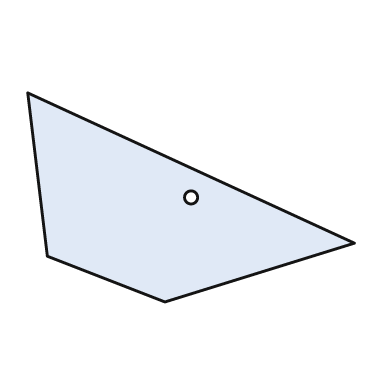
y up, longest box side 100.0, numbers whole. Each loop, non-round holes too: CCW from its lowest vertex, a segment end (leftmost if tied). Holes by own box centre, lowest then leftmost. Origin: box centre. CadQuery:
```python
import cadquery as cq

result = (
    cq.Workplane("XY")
    .moveTo(-8.0, -32.0)
    .lineTo(50.0, -14.0)
    .lineTo(-50.0, 32.0)
    .lineTo(-44.0, -18.0)
    .close()
    .moveTo(0.0, 0.0)
    .circle(2.0)
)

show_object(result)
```